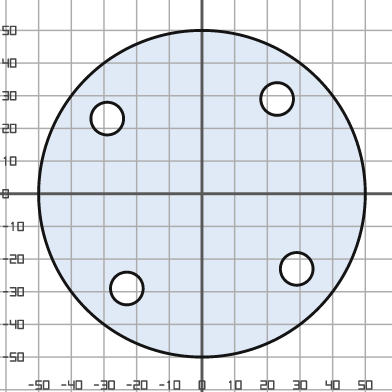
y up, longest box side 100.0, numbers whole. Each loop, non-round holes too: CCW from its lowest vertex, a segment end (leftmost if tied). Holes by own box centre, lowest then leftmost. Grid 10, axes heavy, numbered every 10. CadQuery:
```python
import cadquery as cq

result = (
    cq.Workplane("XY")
    .moveTo(0.0, 0.0)
    .circle(50.0)
    .moveTo(-23.0, -29.0)
    .circle(5.0)
    .moveTo(29.0, -23.0)
    .circle(5.0)
    .moveTo(-29.0, 23.0)
    .circle(5.0)
    .moveTo(23.0, 29.0)
    .circle(5.0)
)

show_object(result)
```